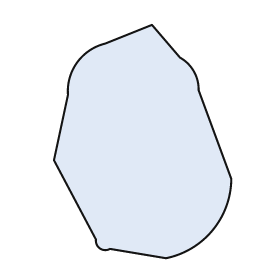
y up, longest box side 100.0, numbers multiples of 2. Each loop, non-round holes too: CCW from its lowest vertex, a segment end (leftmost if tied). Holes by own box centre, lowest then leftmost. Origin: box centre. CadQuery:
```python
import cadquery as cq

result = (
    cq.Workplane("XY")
    .moveTo(10.0, -50.0)
    .threePointArc((30.0, -38.0), (38.0, -16.0))
    .lineTo(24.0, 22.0)
    .threePointArc((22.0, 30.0), (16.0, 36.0))
    .lineTo(4.0, 50.0)
    .lineTo(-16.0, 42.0)
    .threePointArc((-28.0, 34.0), (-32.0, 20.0))
    .lineTo(-38.0, -8.0)
    .lineTo(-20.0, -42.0)
    .threePointArc((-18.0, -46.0), (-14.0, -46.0))
    .close()
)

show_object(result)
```